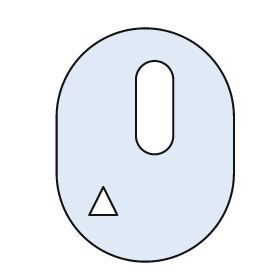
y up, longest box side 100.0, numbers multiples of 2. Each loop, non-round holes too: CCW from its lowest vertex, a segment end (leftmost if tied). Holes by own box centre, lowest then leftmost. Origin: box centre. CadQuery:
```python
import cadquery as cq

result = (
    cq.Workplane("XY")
    .moveTo(-38.0, -12.0)
    .threePointArc((0.0, -50.0), (38.0, -12.0))
    .lineTo(38.0, 12.0)
    .threePointArc((0.0, 50.0), (-38.0, 12.0))
    .close()
    .moveTo(-24.0, -30.0)
    .lineTo(-12.0, -30.0)
    .lineTo(-18.0, -18.0)
    .close()
    .moveTo(-4.0, 4.0)
    .threePointArc((4.0, -4.0), (12.0, 4.0))
    .lineTo(12.0, 28.0)
    .threePointArc((4.0, 36.0), (-4.0, 28.0))
    .close()
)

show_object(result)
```